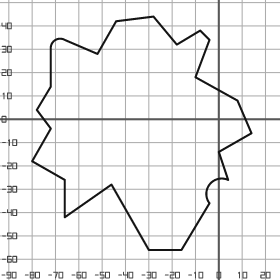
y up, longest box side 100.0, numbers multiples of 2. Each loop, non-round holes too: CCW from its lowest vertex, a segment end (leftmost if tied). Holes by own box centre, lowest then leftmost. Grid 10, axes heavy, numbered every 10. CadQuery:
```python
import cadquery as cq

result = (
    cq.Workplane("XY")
    .moveTo(-30.0, -56.0)
    .lineTo(-16.0, -56.0)
    .lineTo(-4.0, -36.0)
    .threePointArc((-4.0, -28.0), (4.0, -26.0))
    .lineTo(0.0, -14.0)
    .lineTo(14.0, -6.0)
    .lineTo(8.0, 8.0)
    .lineTo(-10.0, 18.0)
    .lineTo(-4.0, 34.0)
    .lineTo(-8.0, 38.0)
    .lineTo(-18.0, 32.0)
    .lineTo(-28.0, 44.0)
    .lineTo(-44.0, 42.0)
    .lineTo(-52.0, 28.0)
    .lineTo(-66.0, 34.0)
    .threePointArc((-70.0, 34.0), (-72.0, 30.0))
    .lineTo(-72.0, 14.0)
    .lineTo(-78.0, 4.0)
    .lineTo(-72.0, -4.0)
    .lineTo(-80.0, -18.0)
    .lineTo(-66.0, -26.0)
    .lineTo(-66.0, -42.0)
    .lineTo(-46.0, -28.0)
    .close()
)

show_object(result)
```